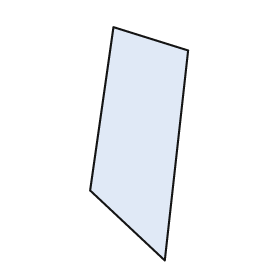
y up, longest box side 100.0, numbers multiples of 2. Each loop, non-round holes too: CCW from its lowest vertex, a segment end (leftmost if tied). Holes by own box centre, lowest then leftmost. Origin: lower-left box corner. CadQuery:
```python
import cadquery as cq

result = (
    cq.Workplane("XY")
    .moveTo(32.0, 0.0)
    .lineTo(42.0, 90.0)
    .lineTo(10.0, 100.0)
    .lineTo(0.0, 30.0)
    .close()
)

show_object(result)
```